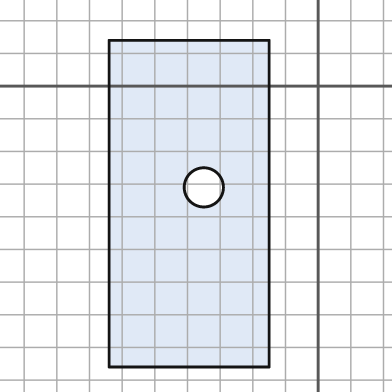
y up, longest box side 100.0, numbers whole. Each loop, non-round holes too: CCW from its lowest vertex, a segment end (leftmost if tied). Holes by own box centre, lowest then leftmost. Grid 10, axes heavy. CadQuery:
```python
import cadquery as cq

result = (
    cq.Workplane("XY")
    .moveTo(-64.0, -86.0)
    .lineTo(-15.0, -86.0)
    .lineTo(-15.0, 14.0)
    .lineTo(-64.0, 14.0)
    .close()
    .moveTo(-35.0, -31.0)
    .circle(6.0)
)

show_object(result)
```